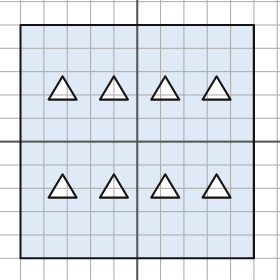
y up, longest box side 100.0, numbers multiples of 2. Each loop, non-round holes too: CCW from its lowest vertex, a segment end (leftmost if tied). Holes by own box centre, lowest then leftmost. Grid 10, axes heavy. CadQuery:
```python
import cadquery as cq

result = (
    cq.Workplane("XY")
    .moveTo(-50.0, -50.0)
    .lineTo(50.0, -50.0)
    .lineTo(50.0, 50.0)
    .lineTo(-50.0, 50.0)
    .close()
    .moveTo(-38.0, -24.0)
    .lineTo(-26.0, -24.0)
    .lineTo(-32.0, -14.0)
    .close()
    .moveTo(-16.0, -24.0)
    .lineTo(-4.0, -24.0)
    .lineTo(-10.0, -14.0)
    .close()
    .moveTo(6.0, -24.0)
    .lineTo(18.0, -24.0)
    .lineTo(12.0, -14.0)
    .close()
    .moveTo(28.0, -24.0)
    .lineTo(40.0, -24.0)
    .lineTo(34.0, -14.0)
    .close()
    .moveTo(-38.0, 18.0)
    .lineTo(-26.0, 18.0)
    .lineTo(-32.0, 28.0)
    .close()
    .moveTo(-16.0, 18.0)
    .lineTo(-4.0, 18.0)
    .lineTo(-10.0, 28.0)
    .close()
    .moveTo(6.0, 18.0)
    .lineTo(18.0, 18.0)
    .lineTo(12.0, 28.0)
    .close()
    .moveTo(28.0, 18.0)
    .lineTo(40.0, 18.0)
    .lineTo(34.0, 28.0)
    .close()
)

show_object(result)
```